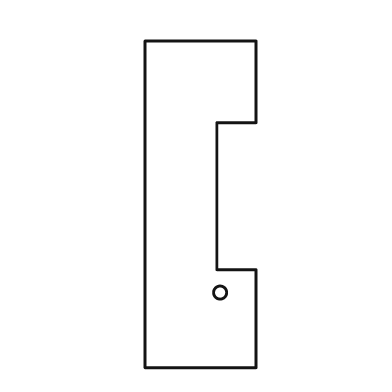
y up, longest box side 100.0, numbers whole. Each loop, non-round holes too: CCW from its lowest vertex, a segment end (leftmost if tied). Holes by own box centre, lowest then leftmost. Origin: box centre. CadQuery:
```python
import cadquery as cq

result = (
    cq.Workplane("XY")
    .moveTo(-17.0, -50.0)
    .lineTo(17.0, -50.0)
    .lineTo(17.0, -20.0)
    .lineTo(5.0, -20.0)
    .lineTo(5.0, 25.0)
    .lineTo(17.0, 25.0)
    .lineTo(17.0, 50.0)
    .lineTo(-17.0, 50.0)
    .close()
    .moveTo(6.0, -27.0)
    .circle(2.0)
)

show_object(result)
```